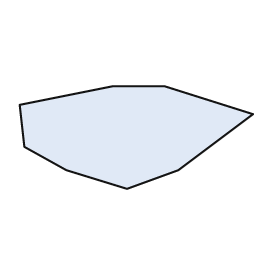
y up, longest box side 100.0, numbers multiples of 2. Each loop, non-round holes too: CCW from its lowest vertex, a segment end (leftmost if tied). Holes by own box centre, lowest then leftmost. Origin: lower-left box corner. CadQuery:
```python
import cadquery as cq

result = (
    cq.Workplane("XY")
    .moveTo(46.0, 0.0)
    .lineTo(68.0, 8.0)
    .lineTo(100.0, 32.0)
    .lineTo(62.0, 44.0)
    .lineTo(40.0, 44.0)
    .lineTo(0.0, 36.0)
    .lineTo(2.0, 18.0)
    .lineTo(20.0, 8.0)
    .close()
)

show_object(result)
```